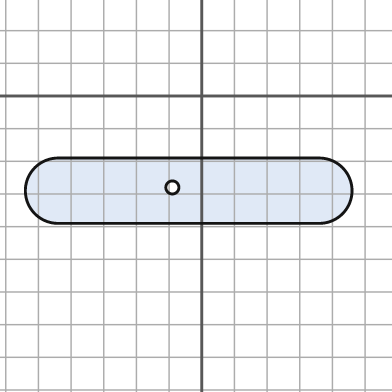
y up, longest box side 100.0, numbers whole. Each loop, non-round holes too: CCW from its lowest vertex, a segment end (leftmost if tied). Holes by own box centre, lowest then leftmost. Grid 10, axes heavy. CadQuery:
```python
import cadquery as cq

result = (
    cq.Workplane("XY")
    .moveTo(-44.0, -39.0)
    .lineTo(36.0, -39.0)
    .threePointArc((46.0, -29.0), (36.0, -19.0))
    .lineTo(-44.0, -19.0)
    .threePointArc((-54.0, -29.0), (-44.0, -39.0))
    .close()
    .moveTo(-9.0, -28.0)
    .circle(2.0)
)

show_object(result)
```